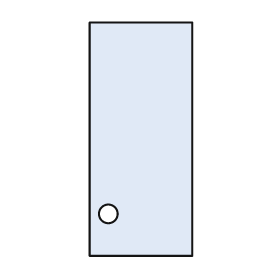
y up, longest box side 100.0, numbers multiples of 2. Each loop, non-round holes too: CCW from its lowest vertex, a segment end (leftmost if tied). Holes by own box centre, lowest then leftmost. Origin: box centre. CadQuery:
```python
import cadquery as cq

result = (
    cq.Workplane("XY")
    .moveTo(-22.0, -50.0)
    .lineTo(22.0, -50.0)
    .lineTo(22.0, 50.0)
    .lineTo(-22.0, 50.0)
    .close()
    .moveTo(-14.0, -32.0)
    .circle(4.0)
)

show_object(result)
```